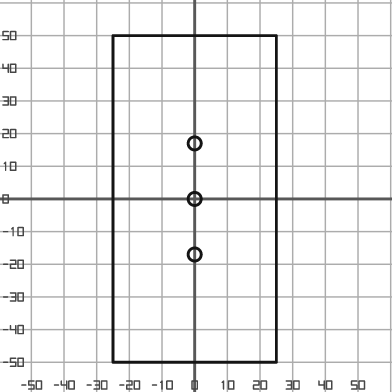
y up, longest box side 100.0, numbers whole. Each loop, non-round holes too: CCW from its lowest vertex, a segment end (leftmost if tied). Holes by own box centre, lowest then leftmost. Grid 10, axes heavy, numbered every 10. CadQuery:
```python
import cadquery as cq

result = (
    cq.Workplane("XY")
    .moveTo(-25.0, -50.0)
    .lineTo(25.0, -50.0)
    .lineTo(25.0, 50.0)
    .lineTo(-25.0, 50.0)
    .close()
    .moveTo(0.0, -17.0)
    .circle(2.0)
    .moveTo(0.0, 0.0)
    .circle(2.0)
    .moveTo(0.0, 17.0)
    .circle(2.0)
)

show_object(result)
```